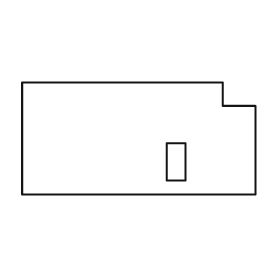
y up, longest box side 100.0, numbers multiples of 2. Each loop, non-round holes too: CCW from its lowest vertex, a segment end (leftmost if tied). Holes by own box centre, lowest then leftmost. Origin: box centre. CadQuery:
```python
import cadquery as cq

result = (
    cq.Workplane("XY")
    .moveTo(-50.0, -24.0)
    .lineTo(50.0, -24.0)
    .lineTo(50.0, 14.0)
    .lineTo(36.0, 14.0)
    .lineTo(36.0, 24.0)
    .lineTo(-50.0, 24.0)
    .close()
    .moveTo(12.0, -18.0)
    .lineTo(20.0, -18.0)
    .lineTo(20.0, -2.0)
    .lineTo(12.0, -2.0)
    .close()
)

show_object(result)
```